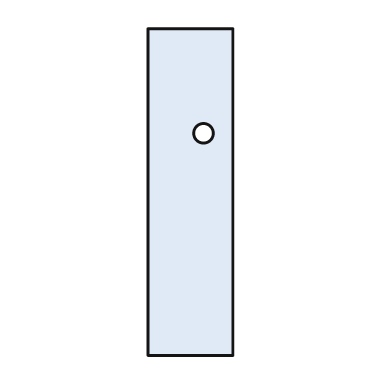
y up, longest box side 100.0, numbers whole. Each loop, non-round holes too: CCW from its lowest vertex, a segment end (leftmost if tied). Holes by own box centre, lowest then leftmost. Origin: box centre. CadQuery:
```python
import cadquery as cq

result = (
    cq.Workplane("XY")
    .moveTo(-13.0, -50.0)
    .lineTo(13.0, -50.0)
    .lineTo(13.0, 50.0)
    .lineTo(-13.0, 50.0)
    .close()
    .moveTo(4.0, 18.0)
    .circle(3.0)
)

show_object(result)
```